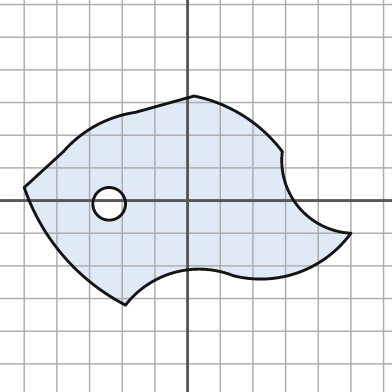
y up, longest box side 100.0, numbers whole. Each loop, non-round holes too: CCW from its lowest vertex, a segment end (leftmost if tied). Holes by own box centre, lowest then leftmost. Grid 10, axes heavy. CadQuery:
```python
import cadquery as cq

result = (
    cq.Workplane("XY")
    .moveTo(-19.0, -32.0)
    .threePointArc((-4.0, -22.0), (14.0, -23.0))
    .threePointArc((34.0, -22.0), (50.0, -10.0))
    .threePointArc((34.0, -2.0), (29.0, 15.0))
    .threePointArc((17.0, 26.0), (2.0, 32.0))
    .lineTo(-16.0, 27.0)
    .threePointArc((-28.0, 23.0), (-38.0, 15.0))
    .lineTo(-50.0, 4.0)
    .threePointArc((-38.0, -17.0), (-19.0, -32.0))
    .close()
    .moveTo(-24.0, -1.0)
    .circle(5.0)
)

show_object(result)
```